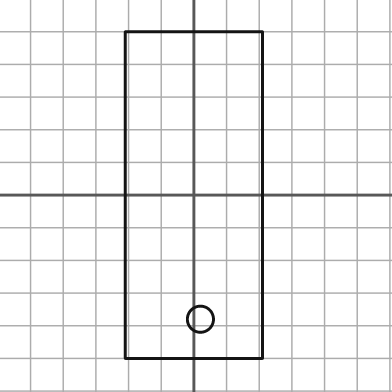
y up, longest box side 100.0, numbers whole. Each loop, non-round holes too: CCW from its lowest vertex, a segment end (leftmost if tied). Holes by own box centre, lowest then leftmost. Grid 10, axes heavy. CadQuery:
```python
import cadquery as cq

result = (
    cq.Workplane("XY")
    .moveTo(-21.0, -50.0)
    .lineTo(21.0, -50.0)
    .lineTo(21.0, 50.0)
    .lineTo(-21.0, 50.0)
    .close()
    .moveTo(2.0, -38.0)
    .circle(4.0)
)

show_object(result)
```